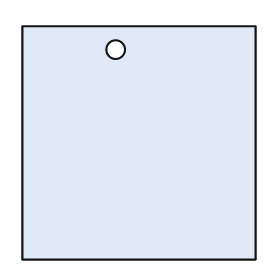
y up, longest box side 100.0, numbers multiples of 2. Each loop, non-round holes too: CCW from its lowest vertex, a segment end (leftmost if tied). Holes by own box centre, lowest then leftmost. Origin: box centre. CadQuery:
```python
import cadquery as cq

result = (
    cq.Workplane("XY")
    .moveTo(-50.0, -50.0)
    .lineTo(50.0, -50.0)
    .lineTo(50.0, 50.0)
    .lineTo(-50.0, 50.0)
    .close()
    .moveTo(-10.0, 40.0)
    .circle(4.0)
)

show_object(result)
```